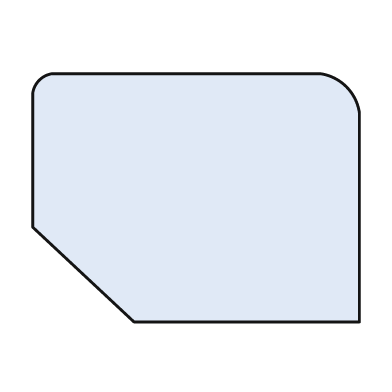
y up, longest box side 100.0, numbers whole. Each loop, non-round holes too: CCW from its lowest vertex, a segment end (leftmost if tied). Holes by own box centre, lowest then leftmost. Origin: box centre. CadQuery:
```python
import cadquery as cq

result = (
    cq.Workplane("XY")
    .moveTo(-19.0, -38.0)
    .lineTo(50.0, -38.0)
    .lineTo(50.0, 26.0)
    .threePointArc((46.0, 34.0), (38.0, 38.0))
    .lineTo(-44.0, 38.0)
    .threePointArc((-48.0, 36.0), (-50.0, 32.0))
    .lineTo(-50.0, -9.0)
    .close()
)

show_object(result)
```